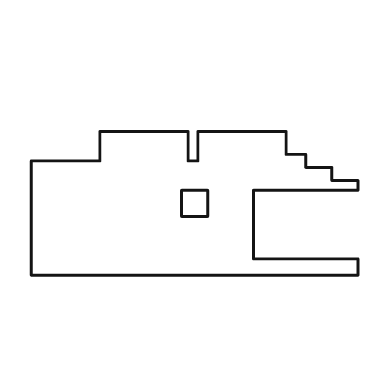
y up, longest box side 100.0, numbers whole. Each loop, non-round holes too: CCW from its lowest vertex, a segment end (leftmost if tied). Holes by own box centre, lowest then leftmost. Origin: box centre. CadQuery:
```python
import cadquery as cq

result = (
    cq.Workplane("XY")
    .moveTo(-50.0, -22.0)
    .lineTo(50.0, -22.0)
    .lineTo(50.0, -17.0)
    .lineTo(18.0, -17.0)
    .lineTo(18.0, 4.0)
    .lineTo(50.0, 4.0)
    .lineTo(50.0, 7.0)
    .lineTo(42.0, 7.0)
    .lineTo(42.0, 11.0)
    .lineTo(34.0, 11.0)
    .lineTo(34.0, 15.0)
    .lineTo(28.0, 15.0)
    .lineTo(28.0, 22.0)
    .lineTo(1.0, 22.0)
    .lineTo(1.0, 13.0)
    .lineTo(-2.0, 13.0)
    .lineTo(-2.0, 22.0)
    .lineTo(-29.0, 22.0)
    .lineTo(-29.0, 13.0)
    .lineTo(-50.0, 13.0)
    .close()
    .moveTo(-4.0, -4.0)
    .lineTo(4.0, -4.0)
    .lineTo(4.0, 4.0)
    .lineTo(-4.0, 4.0)
    .close()
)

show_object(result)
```